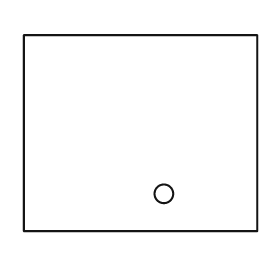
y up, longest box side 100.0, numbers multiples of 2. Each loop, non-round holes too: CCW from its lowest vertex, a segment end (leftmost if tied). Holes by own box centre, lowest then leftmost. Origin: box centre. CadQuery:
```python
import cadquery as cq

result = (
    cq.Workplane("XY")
    .moveTo(-50.0, -42.0)
    .lineTo(50.0, -42.0)
    .lineTo(50.0, 42.0)
    .lineTo(-50.0, 42.0)
    .close()
    .moveTo(10.0, -26.0)
    .circle(4.0)
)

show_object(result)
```